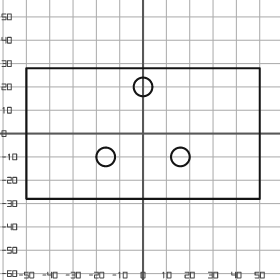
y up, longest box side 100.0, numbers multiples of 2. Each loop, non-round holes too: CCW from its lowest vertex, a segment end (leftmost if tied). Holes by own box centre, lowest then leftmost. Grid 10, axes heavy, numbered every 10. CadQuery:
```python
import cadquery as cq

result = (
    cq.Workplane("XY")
    .moveTo(-50.0, -28.0)
    .lineTo(50.0, -28.0)
    .lineTo(50.0, 28.0)
    .lineTo(-50.0, 28.0)
    .close()
    .moveTo(-16.0, -10.0)
    .circle(4.0)
    .moveTo(16.0, -10.0)
    .circle(4.0)
    .moveTo(0.0, 20.0)
    .circle(4.0)
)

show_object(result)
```